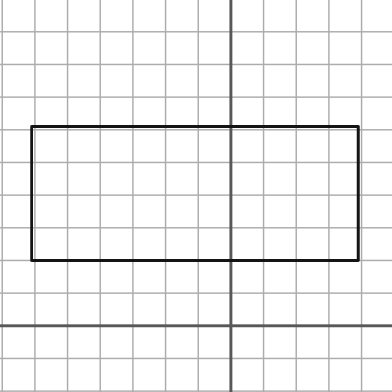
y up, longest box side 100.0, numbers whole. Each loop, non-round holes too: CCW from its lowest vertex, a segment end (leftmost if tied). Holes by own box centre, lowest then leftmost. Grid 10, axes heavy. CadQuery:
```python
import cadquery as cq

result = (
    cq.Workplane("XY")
    .moveTo(-61.0, 20.0)
    .lineTo(39.0, 20.0)
    .lineTo(39.0, 61.0)
    .lineTo(-61.0, 61.0)
    .close()
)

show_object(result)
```